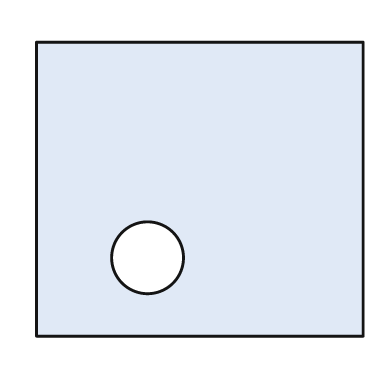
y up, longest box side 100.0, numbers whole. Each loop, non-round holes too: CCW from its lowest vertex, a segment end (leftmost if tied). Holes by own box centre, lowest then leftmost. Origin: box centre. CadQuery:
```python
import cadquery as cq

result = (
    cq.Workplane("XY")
    .moveTo(-50.0, -45.0)
    .lineTo(50.0, -45.0)
    .lineTo(50.0, 45.0)
    .lineTo(-50.0, 45.0)
    .close()
    .moveTo(-16.0, -21.0)
    .circle(11.0)
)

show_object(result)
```